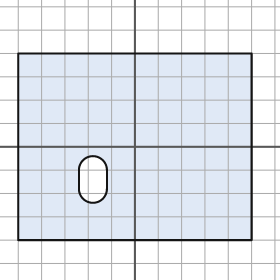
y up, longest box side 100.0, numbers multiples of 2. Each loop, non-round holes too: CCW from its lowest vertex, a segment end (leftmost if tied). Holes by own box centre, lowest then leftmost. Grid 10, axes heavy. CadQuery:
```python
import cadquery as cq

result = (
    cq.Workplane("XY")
    .moveTo(-50.0, -40.0)
    .lineTo(50.0, -40.0)
    .lineTo(50.0, 40.0)
    .lineTo(-50.0, 40.0)
    .close()
    .moveTo(-24.0, -18.0)
    .threePointArc((-18.0, -24.0), (-12.0, -18.0))
    .lineTo(-12.0, -10.0)
    .threePointArc((-18.0, -4.0), (-24.0, -10.0))
    .close()
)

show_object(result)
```